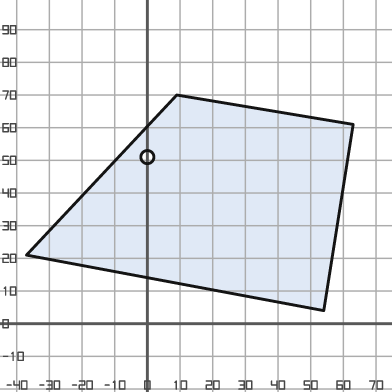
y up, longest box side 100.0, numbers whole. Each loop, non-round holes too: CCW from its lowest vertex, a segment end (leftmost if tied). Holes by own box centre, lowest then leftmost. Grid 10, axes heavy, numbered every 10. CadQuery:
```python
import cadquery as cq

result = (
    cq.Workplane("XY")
    .moveTo(54.0, 4.0)
    .lineTo(63.0, 61.0)
    .lineTo(9.0, 70.0)
    .lineTo(-37.0, 21.0)
    .close()
    .moveTo(0.0, 51.0)
    .circle(2.0)
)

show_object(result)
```